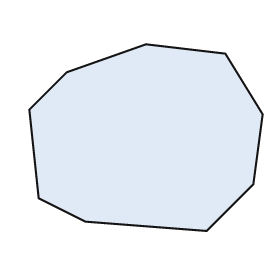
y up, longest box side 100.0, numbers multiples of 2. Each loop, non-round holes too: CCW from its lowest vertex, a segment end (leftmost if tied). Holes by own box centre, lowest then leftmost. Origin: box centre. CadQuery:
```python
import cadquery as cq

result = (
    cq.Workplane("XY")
    .moveTo(26.0, -40.0)
    .lineTo(46.0, -20.0)
    .lineTo(50.0, 10.0)
    .lineTo(34.0, 36.0)
    .lineTo(0.0, 40.0)
    .lineTo(-34.0, 28.0)
    .lineTo(-50.0, 12.0)
    .lineTo(-46.0, -26.0)
    .lineTo(-26.0, -36.0)
    .close()
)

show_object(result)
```